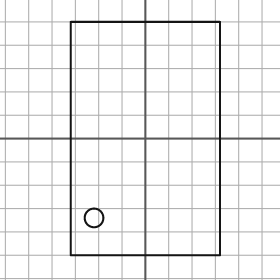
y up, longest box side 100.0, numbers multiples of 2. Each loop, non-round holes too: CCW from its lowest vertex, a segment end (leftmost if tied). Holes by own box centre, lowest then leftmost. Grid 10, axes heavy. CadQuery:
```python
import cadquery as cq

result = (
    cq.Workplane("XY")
    .moveTo(-32.0, -50.0)
    .lineTo(32.0, -50.0)
    .lineTo(32.0, 50.0)
    .lineTo(-32.0, 50.0)
    .close()
    .moveTo(-22.0, -34.0)
    .circle(4.0)
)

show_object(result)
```